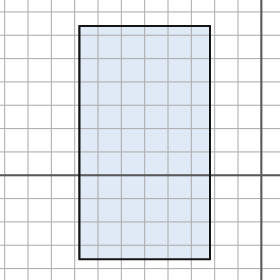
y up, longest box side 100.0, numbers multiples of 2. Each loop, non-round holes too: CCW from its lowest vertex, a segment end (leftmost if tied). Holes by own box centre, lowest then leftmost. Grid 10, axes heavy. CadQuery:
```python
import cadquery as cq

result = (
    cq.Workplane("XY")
    .moveTo(-78.0, -36.0)
    .lineTo(-22.0, -36.0)
    .lineTo(-22.0, 64.0)
    .lineTo(-78.0, 64.0)
    .close()
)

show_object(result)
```